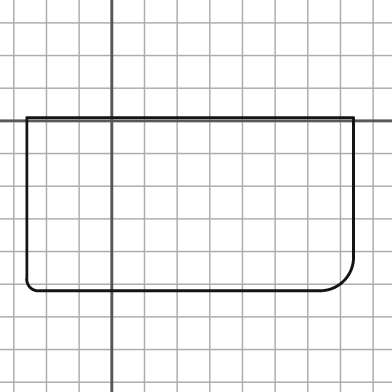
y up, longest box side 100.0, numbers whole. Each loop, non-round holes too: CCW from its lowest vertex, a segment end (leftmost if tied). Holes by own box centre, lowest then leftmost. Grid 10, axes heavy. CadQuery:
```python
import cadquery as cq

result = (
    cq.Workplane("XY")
    .moveTo(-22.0, -52.0)
    .lineTo(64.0, -52.0)
    .threePointArc((71.0, -49.0), (74.0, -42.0))
    .lineTo(74.0, 1.0)
    .lineTo(-26.0, 1.0)
    .lineTo(-26.0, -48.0)
    .threePointArc((-25.0, -51.0), (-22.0, -52.0))
    .close()
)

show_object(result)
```